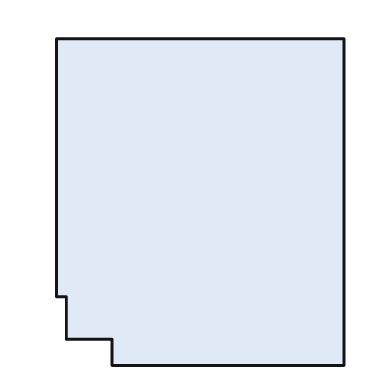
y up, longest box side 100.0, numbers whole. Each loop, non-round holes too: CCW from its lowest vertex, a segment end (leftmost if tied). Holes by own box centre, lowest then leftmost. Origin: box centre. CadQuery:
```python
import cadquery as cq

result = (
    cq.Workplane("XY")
    .moveTo(-27.0, -50.0)
    .lineTo(44.0, -50.0)
    .lineTo(44.0, 50.0)
    .lineTo(-44.0, 50.0)
    .lineTo(-44.0, -29.0)
    .lineTo(-41.0, -29.0)
    .lineTo(-41.0, -42.0)
    .lineTo(-27.0, -42.0)
    .close()
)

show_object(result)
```